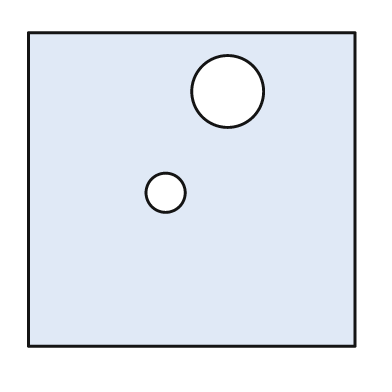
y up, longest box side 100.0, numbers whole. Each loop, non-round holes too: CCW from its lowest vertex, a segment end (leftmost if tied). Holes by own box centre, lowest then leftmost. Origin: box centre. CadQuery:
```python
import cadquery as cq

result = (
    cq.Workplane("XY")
    .moveTo(-50.0, -48.0)
    .lineTo(50.0, -48.0)
    .lineTo(50.0, 48.0)
    .lineTo(-50.0, 48.0)
    .close()
    .moveTo(-8.0, -1.0)
    .circle(6.0)
    .moveTo(11.0, 30.0)
    .circle(11.0)
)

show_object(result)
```